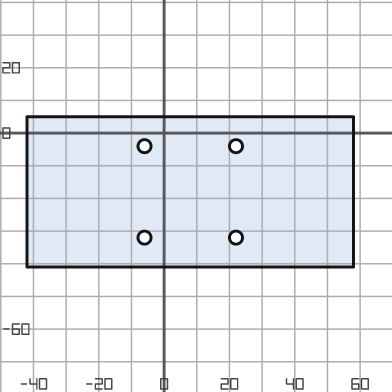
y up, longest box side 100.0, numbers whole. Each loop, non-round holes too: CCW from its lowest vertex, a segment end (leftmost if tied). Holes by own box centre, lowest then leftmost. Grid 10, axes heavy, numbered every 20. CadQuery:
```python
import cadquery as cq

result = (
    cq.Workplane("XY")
    .moveTo(-42.0, -41.0)
    .lineTo(58.0, -41.0)
    .lineTo(58.0, 5.0)
    .lineTo(-42.0, 5.0)
    .close()
    .moveTo(-6.0, -32.0)
    .circle(2.0)
    .moveTo(22.0, -32.0)
    .circle(2.0)
    .moveTo(-6.0, -4.0)
    .circle(2.0)
    .moveTo(22.0, -4.0)
    .circle(2.0)
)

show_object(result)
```